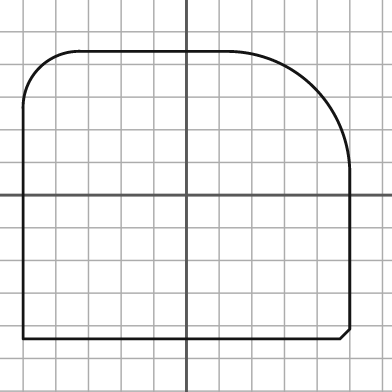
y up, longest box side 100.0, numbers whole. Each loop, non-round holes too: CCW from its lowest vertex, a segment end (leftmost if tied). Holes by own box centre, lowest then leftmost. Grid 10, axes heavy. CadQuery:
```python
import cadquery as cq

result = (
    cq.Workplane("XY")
    .moveTo(-50.0, -44.0)
    .lineTo(47.0, -44.0)
    .lineTo(50.0, -41.0)
    .lineTo(50.0, 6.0)
    .threePointArc((39.0, 33.0), (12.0, 44.0))
    .lineTo(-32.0, 44.0)
    .threePointArc((-45.0, 39.0), (-50.0, 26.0))
    .close()
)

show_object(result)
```